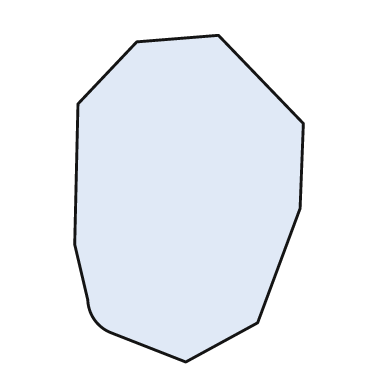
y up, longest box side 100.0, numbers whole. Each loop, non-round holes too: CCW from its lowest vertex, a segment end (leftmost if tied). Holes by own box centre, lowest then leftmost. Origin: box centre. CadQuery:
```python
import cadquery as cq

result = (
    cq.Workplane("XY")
    .moveTo(-1.0, -50.0)
    .lineTo(21.0, -38.0)
    .lineTo(34.0, -3.0)
    .lineTo(35.0, 23.0)
    .lineTo(9.0, 50.0)
    .lineTo(-16.0, 48.0)
    .lineTo(-34.0, 29.0)
    .lineTo(-35.0, -14.0)
    .lineTo(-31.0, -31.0)
    .threePointArc((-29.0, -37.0), (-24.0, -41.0))
    .close()
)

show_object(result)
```